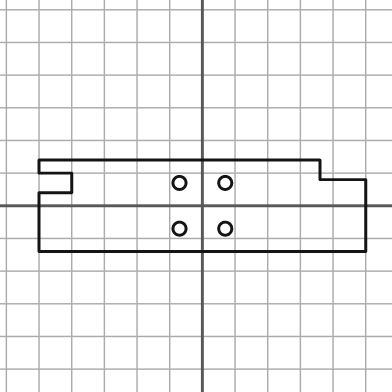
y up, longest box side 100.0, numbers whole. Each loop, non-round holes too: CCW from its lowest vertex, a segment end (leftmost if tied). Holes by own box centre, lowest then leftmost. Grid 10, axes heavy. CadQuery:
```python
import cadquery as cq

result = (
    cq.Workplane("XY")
    .moveTo(-50.0, -14.0)
    .lineTo(50.0, -14.0)
    .lineTo(50.0, 8.0)
    .lineTo(36.0, 8.0)
    .lineTo(36.0, 14.0)
    .lineTo(-50.0, 14.0)
    .lineTo(-50.0, 10.0)
    .lineTo(-40.0, 10.0)
    .lineTo(-40.0, 4.0)
    .lineTo(-50.0, 4.0)
    .close()
    .moveTo(-7.0, -7.0)
    .circle(2.0)
    .moveTo(7.0, -7.0)
    .circle(2.0)
    .moveTo(-7.0, 7.0)
    .circle(2.0)
    .moveTo(7.0, 7.0)
    .circle(2.0)
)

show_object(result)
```